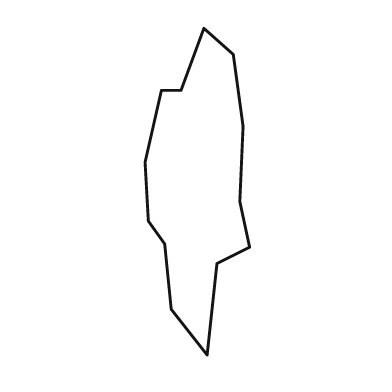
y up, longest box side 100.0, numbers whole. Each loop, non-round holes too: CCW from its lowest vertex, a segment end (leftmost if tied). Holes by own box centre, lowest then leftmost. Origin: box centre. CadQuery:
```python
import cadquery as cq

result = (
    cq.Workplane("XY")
    .moveTo(3.0, -50.0)
    .lineTo(6.0, -22.0)
    .lineTo(16.0, -17.0)
    .lineTo(13.0, -3.0)
    .lineTo(14.0, 20.0)
    .lineTo(11.0, 42.0)
    .lineTo(2.0, 50.0)
    .lineTo(-5.0, 31.0)
    .lineTo(-11.0, 31.0)
    .lineTo(-16.0, 9.0)
    .lineTo(-15.0, -9.0)
    .lineTo(-10.0, -16.0)
    .lineTo(-8.0, -36.0)
    .close()
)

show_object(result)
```